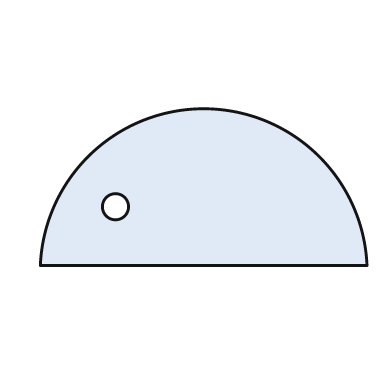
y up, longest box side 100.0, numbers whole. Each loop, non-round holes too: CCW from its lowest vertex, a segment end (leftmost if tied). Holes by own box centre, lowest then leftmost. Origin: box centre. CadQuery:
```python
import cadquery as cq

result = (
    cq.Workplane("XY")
    .moveTo(-50.0, -24.0)
    .lineTo(50.0, -24.0)
    .threePointArc((0.0, 24.0), (-50.0, -24.0))
    .close()
    .moveTo(-27.0, -6.0)
    .circle(4.0)
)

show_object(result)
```